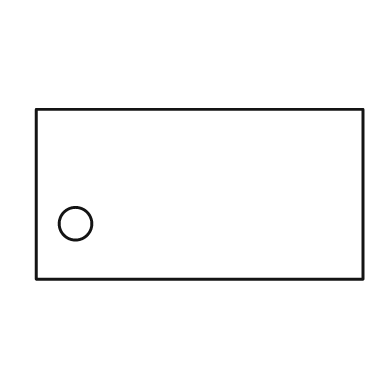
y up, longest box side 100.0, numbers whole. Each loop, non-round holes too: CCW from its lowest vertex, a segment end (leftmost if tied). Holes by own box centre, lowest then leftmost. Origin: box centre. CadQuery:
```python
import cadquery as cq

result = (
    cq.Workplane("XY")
    .moveTo(-50.0, -26.0)
    .lineTo(50.0, -26.0)
    .lineTo(50.0, 26.0)
    .lineTo(-50.0, 26.0)
    .close()
    .moveTo(-38.0, -9.0)
    .circle(5.0)
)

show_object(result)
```